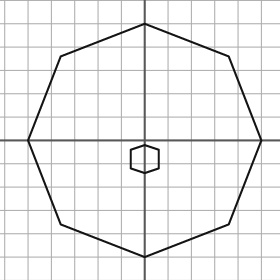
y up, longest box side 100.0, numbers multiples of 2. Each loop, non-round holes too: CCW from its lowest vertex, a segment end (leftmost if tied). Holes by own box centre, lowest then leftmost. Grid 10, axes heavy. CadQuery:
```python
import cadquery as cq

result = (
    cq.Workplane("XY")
    .moveTo(0.0, -50.0)
    .lineTo(36.0, -36.0)
    .lineTo(50.0, 0.0)
    .lineTo(36.0, 36.0)
    .lineTo(0.0, 50.0)
    .lineTo(-36.0, 36.0)
    .lineTo(-50.0, 0.0)
    .lineTo(-36.0, -36.0)
    .close()
    .moveTo(0.0, -14.0)
    .lineTo(6.0, -12.0)
    .lineTo(6.0, -4.0)
    .lineTo(0.0, -2.0)
    .lineTo(-6.0, -4.0)
    .lineTo(-6.0, -12.0)
    .close()
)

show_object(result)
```